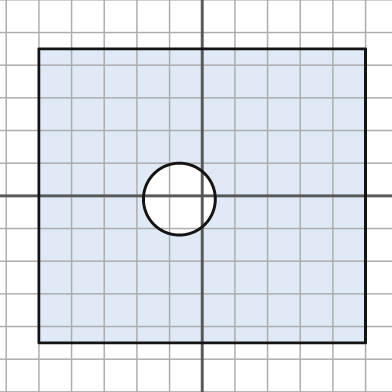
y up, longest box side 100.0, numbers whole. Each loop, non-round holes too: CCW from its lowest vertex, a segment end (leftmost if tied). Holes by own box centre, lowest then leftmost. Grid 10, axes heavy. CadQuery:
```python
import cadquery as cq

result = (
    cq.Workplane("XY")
    .moveTo(-50.0, -45.0)
    .lineTo(50.0, -45.0)
    .lineTo(50.0, 45.0)
    .lineTo(-50.0, 45.0)
    .close()
    .moveTo(-7.0, -1.0)
    .circle(11.0)
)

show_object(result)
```